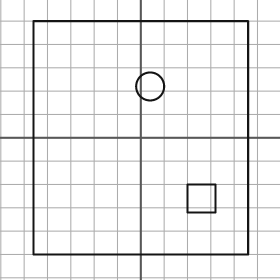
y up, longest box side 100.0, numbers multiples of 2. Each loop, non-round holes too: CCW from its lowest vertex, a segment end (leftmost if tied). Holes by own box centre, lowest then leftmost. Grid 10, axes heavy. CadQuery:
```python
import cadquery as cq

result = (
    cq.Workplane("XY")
    .moveTo(-46.0, -50.0)
    .lineTo(46.0, -50.0)
    .lineTo(46.0, 50.0)
    .lineTo(-46.0, 50.0)
    .close()
    .moveTo(20.0, -32.0)
    .lineTo(32.0, -32.0)
    .lineTo(32.0, -20.0)
    .lineTo(20.0, -20.0)
    .close()
    .moveTo(4.0, 22.0)
    .circle(6.0)
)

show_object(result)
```